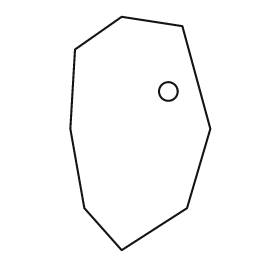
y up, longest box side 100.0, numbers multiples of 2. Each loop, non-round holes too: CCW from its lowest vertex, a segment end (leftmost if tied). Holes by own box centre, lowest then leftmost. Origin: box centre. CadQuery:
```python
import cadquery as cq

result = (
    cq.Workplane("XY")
    .moveTo(-8.0, -50.0)
    .lineTo(20.0, -32.0)
    .lineTo(30.0, 2.0)
    .lineTo(18.0, 46.0)
    .lineTo(-8.0, 50.0)
    .lineTo(-28.0, 36.0)
    .lineTo(-30.0, 2.0)
    .lineTo(-24.0, -32.0)
    .close()
    .moveTo(12.0, 18.0)
    .circle(4.0)
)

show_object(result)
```